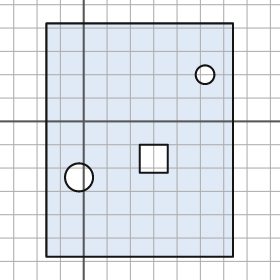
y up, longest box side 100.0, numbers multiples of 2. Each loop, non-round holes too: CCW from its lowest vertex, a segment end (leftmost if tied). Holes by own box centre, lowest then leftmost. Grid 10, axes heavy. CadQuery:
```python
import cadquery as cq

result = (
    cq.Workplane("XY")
    .moveTo(-16.0, -58.0)
    .lineTo(64.0, -58.0)
    .lineTo(64.0, 42.0)
    .lineTo(-16.0, 42.0)
    .close()
    .moveTo(-2.0, -24.0)
    .circle(6.0)
    .moveTo(24.0, -22.0)
    .lineTo(36.0, -22.0)
    .lineTo(36.0, -10.0)
    .lineTo(24.0, -10.0)
    .close()
    .moveTo(52.0, 20.0)
    .circle(4.0)
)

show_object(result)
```